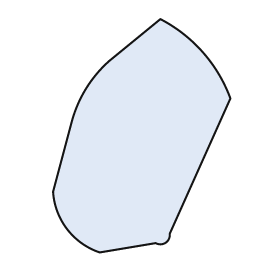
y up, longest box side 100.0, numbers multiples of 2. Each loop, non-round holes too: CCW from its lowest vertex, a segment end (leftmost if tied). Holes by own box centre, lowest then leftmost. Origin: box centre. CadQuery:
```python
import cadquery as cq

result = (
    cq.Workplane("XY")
    .moveTo(-18.0, -50.0)
    .lineTo(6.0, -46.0)
    .threePointArc((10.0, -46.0), (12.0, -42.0))
    .lineTo(38.0, 16.0)
    .threePointArc((26.0, 36.0), (8.0, 50.0))
    .lineTo(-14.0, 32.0)
    .threePointArc((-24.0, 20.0), (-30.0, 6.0))
    .lineTo(-38.0, -24.0)
    .threePointArc((-32.0, -40.0), (-18.0, -50.0))
    .close()
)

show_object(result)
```